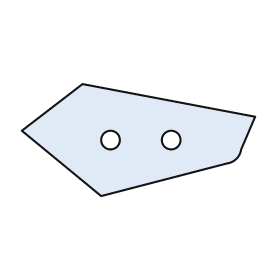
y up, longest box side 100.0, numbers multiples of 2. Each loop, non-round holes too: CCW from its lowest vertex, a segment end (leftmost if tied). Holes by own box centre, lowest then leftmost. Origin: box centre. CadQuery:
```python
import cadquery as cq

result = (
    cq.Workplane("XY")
    .moveTo(-16.0, -24.0)
    .lineTo(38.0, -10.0)
    .threePointArc((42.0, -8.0), (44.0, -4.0))
    .lineTo(50.0, 10.0)
    .lineTo(-24.0, 24.0)
    .lineTo(-50.0, 4.0)
    .close()
    .moveTo(-12.0, 0.0)
    .circle(4.0)
    .moveTo(14.0, 0.0)
    .circle(4.0)
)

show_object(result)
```